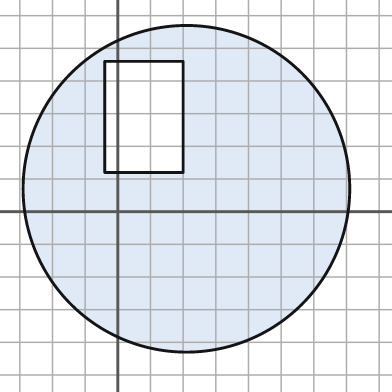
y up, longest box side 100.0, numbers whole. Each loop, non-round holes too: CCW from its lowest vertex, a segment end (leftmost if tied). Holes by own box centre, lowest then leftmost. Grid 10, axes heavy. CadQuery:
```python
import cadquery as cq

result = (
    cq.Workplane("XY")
    .moveTo(21.0, 7.0)
    .circle(50.0)
    .moveTo(-4.0, 12.0)
    .lineTo(20.0, 12.0)
    .lineTo(20.0, 46.0)
    .lineTo(-4.0, 46.0)
    .close()
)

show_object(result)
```